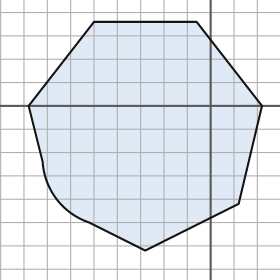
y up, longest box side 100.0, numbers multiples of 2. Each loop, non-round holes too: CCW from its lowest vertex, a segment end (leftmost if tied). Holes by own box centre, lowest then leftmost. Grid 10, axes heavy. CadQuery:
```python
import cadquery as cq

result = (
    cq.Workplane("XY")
    .moveTo(-28.0, -62.0)
    .lineTo(12.0, -42.0)
    .lineTo(22.0, 0.0)
    .lineTo(-6.0, 36.0)
    .lineTo(-50.0, 36.0)
    .lineTo(-78.0, 0.0)
    .lineTo(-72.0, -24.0)
    .threePointArc((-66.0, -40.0), (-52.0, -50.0))
    .close()
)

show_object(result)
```